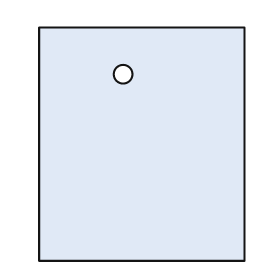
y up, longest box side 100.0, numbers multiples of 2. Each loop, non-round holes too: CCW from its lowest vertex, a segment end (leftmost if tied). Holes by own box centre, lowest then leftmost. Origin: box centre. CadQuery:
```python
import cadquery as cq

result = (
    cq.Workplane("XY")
    .moveTo(-44.0, -50.0)
    .lineTo(44.0, -50.0)
    .lineTo(44.0, 50.0)
    .lineTo(-44.0, 50.0)
    .close()
    .moveTo(-8.0, 30.0)
    .circle(4.0)
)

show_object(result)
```